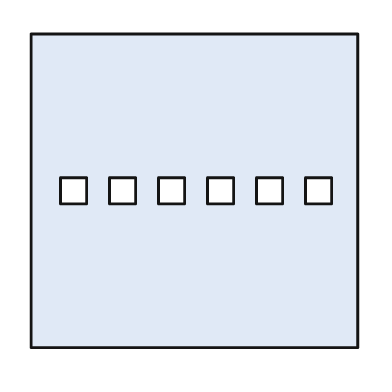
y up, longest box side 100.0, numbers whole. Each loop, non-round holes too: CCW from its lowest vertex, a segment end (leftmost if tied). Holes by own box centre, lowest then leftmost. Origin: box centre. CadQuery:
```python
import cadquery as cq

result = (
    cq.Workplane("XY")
    .moveTo(-50.0, -48.0)
    .lineTo(50.0, -48.0)
    .lineTo(50.0, 48.0)
    .lineTo(-50.0, 48.0)
    .close()
    .moveTo(-41.0, -4.0)
    .lineTo(-33.0, -4.0)
    .lineTo(-33.0, 4.0)
    .lineTo(-41.0, 4.0)
    .close()
    .moveTo(-26.0, -4.0)
    .lineTo(-18.0, -4.0)
    .lineTo(-18.0, 4.0)
    .lineTo(-26.0, 4.0)
    .close()
    .moveTo(-11.0, -4.0)
    .lineTo(-3.0, -4.0)
    .lineTo(-3.0, 4.0)
    .lineTo(-11.0, 4.0)
    .close()
    .moveTo(4.0, -4.0)
    .lineTo(12.0, -4.0)
    .lineTo(12.0, 4.0)
    .lineTo(4.0, 4.0)
    .close()
    .moveTo(19.0, -4.0)
    .lineTo(27.0, -4.0)
    .lineTo(27.0, 4.0)
    .lineTo(19.0, 4.0)
    .close()
    .moveTo(34.0, -4.0)
    .lineTo(42.0, -4.0)
    .lineTo(42.0, 4.0)
    .lineTo(34.0, 4.0)
    .close()
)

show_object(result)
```